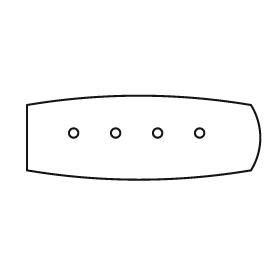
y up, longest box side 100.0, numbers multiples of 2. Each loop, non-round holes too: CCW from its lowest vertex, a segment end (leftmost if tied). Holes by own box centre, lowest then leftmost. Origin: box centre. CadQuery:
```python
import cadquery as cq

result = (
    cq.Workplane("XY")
    .moveTo(-50.0, -14.0)
    .threePointArc((-2.0, -18.0), (46.0, -14.0))
    .threePointArc((50.0, 0.0), (46.0, 14.0))
    .threePointArc((-2.0, 18.0), (-50.0, 14.0))
    .close()
    .moveTo(-30.0, 2.0)
    .circle(2.0)
    .moveTo(-12.0, 2.0)
    .circle(2.0)
    .moveTo(6.0, 2.0)
    .circle(2.0)
    .moveTo(24.0, 2.0)
    .circle(2.0)
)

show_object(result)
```